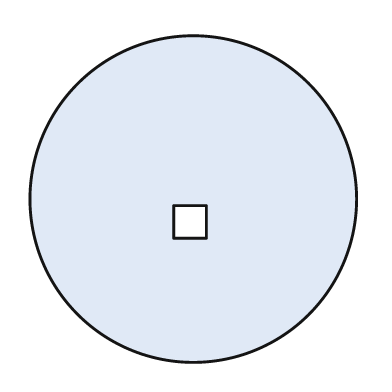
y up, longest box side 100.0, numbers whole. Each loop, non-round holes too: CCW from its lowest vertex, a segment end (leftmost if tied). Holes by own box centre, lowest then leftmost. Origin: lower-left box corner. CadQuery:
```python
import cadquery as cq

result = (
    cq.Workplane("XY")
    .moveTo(50.0, 50.0)
    .circle(50.0)
    .moveTo(44.0, 38.0)
    .lineTo(54.0, 38.0)
    .lineTo(54.0, 48.0)
    .lineTo(44.0, 48.0)
    .close()
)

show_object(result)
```